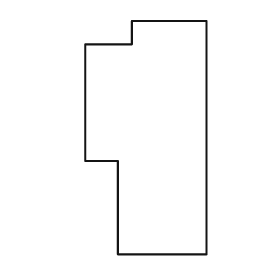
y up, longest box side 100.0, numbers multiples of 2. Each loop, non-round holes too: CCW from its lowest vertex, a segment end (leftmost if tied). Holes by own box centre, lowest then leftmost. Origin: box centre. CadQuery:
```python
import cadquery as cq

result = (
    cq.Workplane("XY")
    .moveTo(-12.0, -50.0)
    .lineTo(26.0, -50.0)
    .lineTo(26.0, 50.0)
    .lineTo(-6.0, 50.0)
    .lineTo(-6.0, 40.0)
    .lineTo(-26.0, 40.0)
    .lineTo(-26.0, -10.0)
    .lineTo(-12.0, -10.0)
    .close()
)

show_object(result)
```